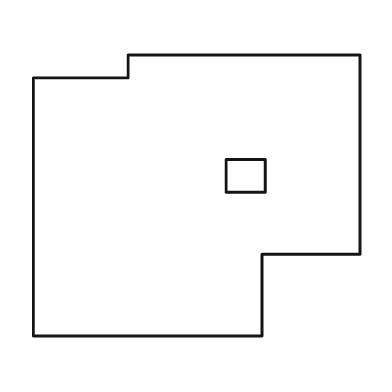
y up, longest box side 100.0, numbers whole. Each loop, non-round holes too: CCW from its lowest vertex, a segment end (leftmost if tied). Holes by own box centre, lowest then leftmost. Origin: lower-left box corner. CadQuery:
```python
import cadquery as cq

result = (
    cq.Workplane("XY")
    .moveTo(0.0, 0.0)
    .lineTo(70.0, 0.0)
    .lineTo(70.0, 25.0)
    .lineTo(100.0, 25.0)
    .lineTo(100.0, 86.0)
    .lineTo(29.0, 86.0)
    .lineTo(29.0, 79.0)
    .lineTo(0.0, 79.0)
    .close()
    .moveTo(59.0, 44.0)
    .lineTo(71.0, 44.0)
    .lineTo(71.0, 54.0)
    .lineTo(59.0, 54.0)
    .close()
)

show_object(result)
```